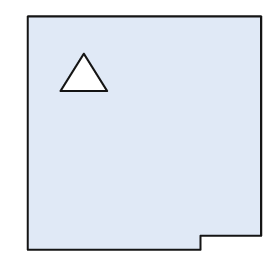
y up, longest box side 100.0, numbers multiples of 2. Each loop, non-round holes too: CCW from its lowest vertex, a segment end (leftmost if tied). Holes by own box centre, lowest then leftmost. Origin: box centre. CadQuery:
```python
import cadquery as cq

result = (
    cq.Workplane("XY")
    .moveTo(-50.0, -50.0)
    .lineTo(24.0, -50.0)
    .lineTo(24.0, -44.0)
    .lineTo(50.0, -44.0)
    .lineTo(50.0, 50.0)
    .lineTo(-50.0, 50.0)
    .close()
    .moveTo(-36.0, 18.0)
    .lineTo(-16.0, 18.0)
    .lineTo(-26.0, 34.0)
    .close()
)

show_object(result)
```